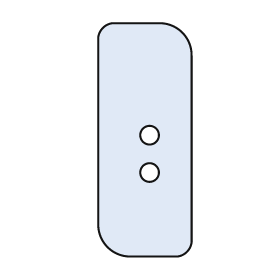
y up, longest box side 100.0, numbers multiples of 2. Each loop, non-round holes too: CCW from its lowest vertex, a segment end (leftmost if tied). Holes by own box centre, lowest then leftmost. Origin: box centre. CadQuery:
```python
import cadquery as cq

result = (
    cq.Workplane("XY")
    .moveTo(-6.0, -50.0)
    .lineTo(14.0, -50.0)
    .threePointArc((18.0, -48.0), (20.0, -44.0))
    .lineTo(20.0, 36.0)
    .threePointArc((16.0, 46.0), (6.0, 50.0))
    .lineTo(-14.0, 50.0)
    .threePointArc((-18.0, 48.0), (-20.0, 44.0))
    .lineTo(-20.0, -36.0)
    .threePointArc((-16.0, -46.0), (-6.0, -50.0))
    .close()
    .moveTo(2.0, -14.0)
    .circle(4.0)
    .moveTo(2.0, 2.0)
    .circle(4.0)
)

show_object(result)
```